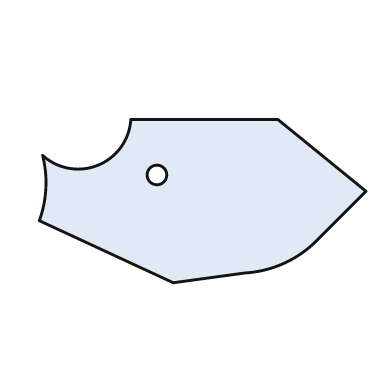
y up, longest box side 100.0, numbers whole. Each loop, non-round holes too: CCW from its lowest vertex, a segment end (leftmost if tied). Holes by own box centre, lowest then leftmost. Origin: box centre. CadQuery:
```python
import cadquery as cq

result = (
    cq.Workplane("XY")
    .moveTo(-9.0, -25.0)
    .lineTo(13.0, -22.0)
    .threePointArc((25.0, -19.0), (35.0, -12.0))
    .lineTo(50.0, 3.0)
    .lineTo(23.0, 25.0)
    .lineTo(-22.0, 25.0)
    .threePointArc((-32.0, 11.0), (-49.0, 14.0))
    .threePointArc((-48.0, 4.0), (-50.0, -6.0))
    .close()
    .moveTo(-14.0, 8.0)
    .circle(3.0)
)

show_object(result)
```